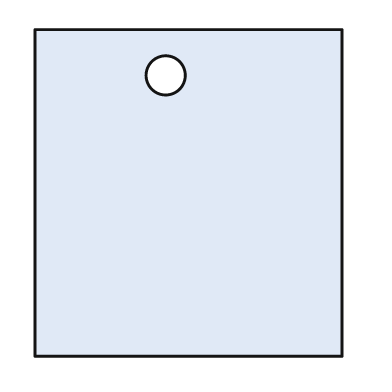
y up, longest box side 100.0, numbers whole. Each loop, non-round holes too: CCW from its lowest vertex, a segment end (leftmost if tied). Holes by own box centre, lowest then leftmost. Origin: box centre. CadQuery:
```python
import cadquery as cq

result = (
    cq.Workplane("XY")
    .moveTo(-47.0, -50.0)
    .lineTo(47.0, -50.0)
    .lineTo(47.0, 50.0)
    .lineTo(-47.0, 50.0)
    .close()
    .moveTo(-7.0, 36.0)
    .circle(6.0)
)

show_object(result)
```